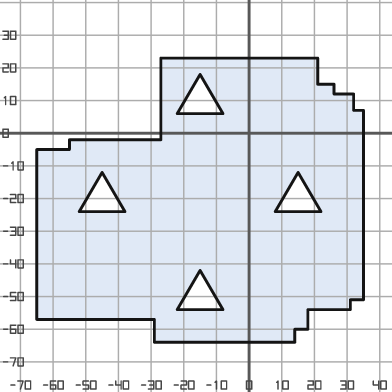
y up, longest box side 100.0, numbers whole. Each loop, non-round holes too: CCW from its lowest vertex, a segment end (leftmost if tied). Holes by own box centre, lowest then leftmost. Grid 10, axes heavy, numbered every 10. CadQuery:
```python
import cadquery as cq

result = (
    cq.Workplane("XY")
    .moveTo(-29.0, -64.0)
    .lineTo(14.0, -64.0)
    .lineTo(14.0, -60.0)
    .lineTo(18.0, -60.0)
    .lineTo(18.0, -54.0)
    .lineTo(31.0, -54.0)
    .lineTo(31.0, -51.0)
    .lineTo(35.0, -51.0)
    .lineTo(35.0, 7.0)
    .lineTo(32.0, 7.0)
    .lineTo(32.0, 12.0)
    .lineTo(26.0, 12.0)
    .lineTo(26.0, 15.0)
    .lineTo(21.0, 15.0)
    .lineTo(21.0, 23.0)
    .lineTo(-27.0, 23.0)
    .lineTo(-27.0, -2.0)
    .lineTo(-55.0, -2.0)
    .lineTo(-55.0, -5.0)
    .lineTo(-65.0, -5.0)
    .lineTo(-65.0, -57.0)
    .lineTo(-29.0, -57.0)
    .close()
    .moveTo(-22.0, -54.0)
    .lineTo(-8.0, -54.0)
    .lineTo(-15.0, -42.0)
    .close()
    .moveTo(-52.0, -24.0)
    .lineTo(-38.0, -24.0)
    .lineTo(-45.0, -12.0)
    .close()
    .moveTo(8.0, -24.0)
    .lineTo(22.0, -24.0)
    .lineTo(15.0, -12.0)
    .close()
    .moveTo(-22.0, 6.0)
    .lineTo(-8.0, 6.0)
    .lineTo(-15.0, 18.0)
    .close()
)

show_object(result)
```